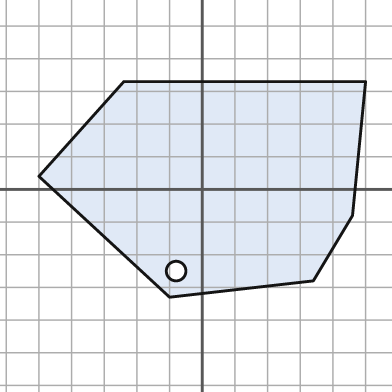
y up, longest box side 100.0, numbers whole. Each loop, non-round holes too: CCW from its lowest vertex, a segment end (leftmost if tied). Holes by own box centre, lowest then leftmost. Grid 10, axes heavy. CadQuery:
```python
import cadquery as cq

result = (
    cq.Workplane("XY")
    .moveTo(-10.0, -33.0)
    .lineTo(34.0, -28.0)
    .lineTo(46.0, -8.0)
    .lineTo(50.0, 33.0)
    .lineTo(-24.0, 33.0)
    .lineTo(-50.0, 4.0)
    .close()
    .moveTo(-8.0, -25.0)
    .circle(3.0)
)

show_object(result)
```